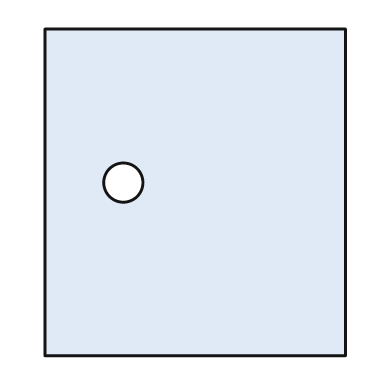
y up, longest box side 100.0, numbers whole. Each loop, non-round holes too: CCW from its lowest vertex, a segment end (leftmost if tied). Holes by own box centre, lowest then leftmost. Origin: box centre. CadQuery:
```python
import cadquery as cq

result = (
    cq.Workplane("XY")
    .moveTo(-46.0, -50.0)
    .lineTo(46.0, -50.0)
    .lineTo(46.0, 50.0)
    .lineTo(-46.0, 50.0)
    .close()
    .moveTo(-22.0, 3.0)
    .circle(6.0)
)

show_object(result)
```